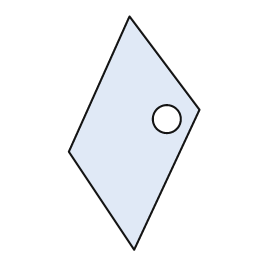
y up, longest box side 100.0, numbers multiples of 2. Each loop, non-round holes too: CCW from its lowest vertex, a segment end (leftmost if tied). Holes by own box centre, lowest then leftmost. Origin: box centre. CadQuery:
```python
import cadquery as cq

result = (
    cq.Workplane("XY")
    .moveTo(0.0, -50.0)
    .lineTo(28.0, 10.0)
    .lineTo(-2.0, 50.0)
    .lineTo(-28.0, -8.0)
    .close()
    .moveTo(14.0, 6.0)
    .circle(6.0)
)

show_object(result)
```